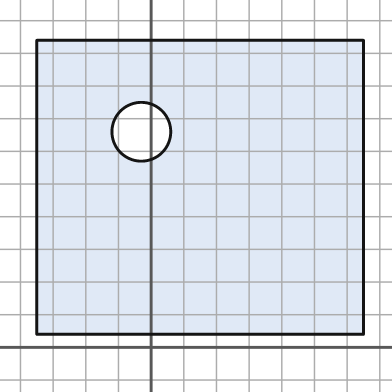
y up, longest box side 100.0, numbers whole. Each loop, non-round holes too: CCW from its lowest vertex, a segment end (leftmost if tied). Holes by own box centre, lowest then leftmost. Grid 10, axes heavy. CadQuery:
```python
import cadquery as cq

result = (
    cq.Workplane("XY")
    .moveTo(-35.0, 4.0)
    .lineTo(65.0, 4.0)
    .lineTo(65.0, 94.0)
    .lineTo(-35.0, 94.0)
    .close()
    .moveTo(-3.0, 66.0)
    .circle(9.0)
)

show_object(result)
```